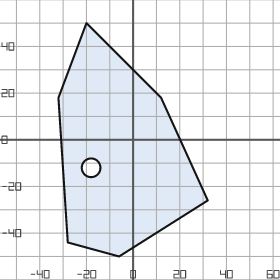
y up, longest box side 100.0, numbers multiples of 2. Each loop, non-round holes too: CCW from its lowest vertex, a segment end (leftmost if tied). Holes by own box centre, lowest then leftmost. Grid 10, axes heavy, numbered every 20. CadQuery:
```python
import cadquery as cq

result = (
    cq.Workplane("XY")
    .moveTo(-6.0, -50.0)
    .lineTo(32.0, -26.0)
    .lineTo(12.0, 18.0)
    .lineTo(-20.0, 50.0)
    .lineTo(-32.0, 18.0)
    .lineTo(-28.0, -44.0)
    .close()
    .moveTo(-18.0, -12.0)
    .circle(4.0)
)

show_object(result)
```